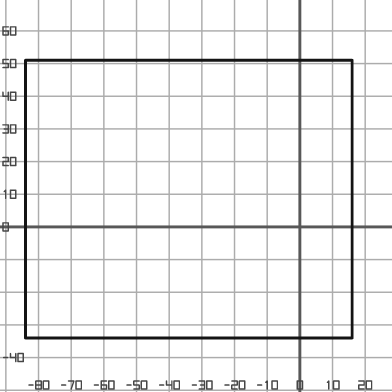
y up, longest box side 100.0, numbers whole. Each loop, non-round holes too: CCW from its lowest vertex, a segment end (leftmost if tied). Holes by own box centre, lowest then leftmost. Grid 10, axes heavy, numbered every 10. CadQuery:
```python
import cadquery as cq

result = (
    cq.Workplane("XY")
    .moveTo(-84.0, -34.0)
    .lineTo(16.0, -34.0)
    .lineTo(16.0, 51.0)
    .lineTo(-84.0, 51.0)
    .close()
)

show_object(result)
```